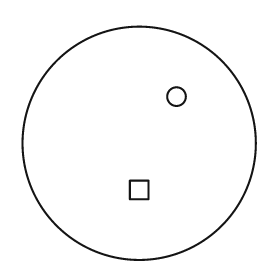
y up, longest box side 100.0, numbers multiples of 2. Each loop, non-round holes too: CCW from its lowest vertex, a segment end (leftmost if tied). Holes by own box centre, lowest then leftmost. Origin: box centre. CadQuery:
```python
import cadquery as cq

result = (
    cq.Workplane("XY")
    .moveTo(0.0, 0.0)
    .circle(50.0)
    .moveTo(-4.0, -24.0)
    .lineTo(4.0, -24.0)
    .lineTo(4.0, -16.0)
    .lineTo(-4.0, -16.0)
    .close()
    .moveTo(16.0, 20.0)
    .circle(4.0)
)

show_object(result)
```